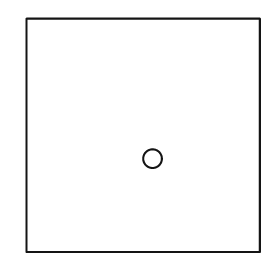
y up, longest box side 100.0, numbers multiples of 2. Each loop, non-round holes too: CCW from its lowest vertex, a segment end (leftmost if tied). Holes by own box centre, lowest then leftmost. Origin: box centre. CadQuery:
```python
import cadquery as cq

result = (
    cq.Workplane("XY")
    .moveTo(-50.0, -50.0)
    .lineTo(50.0, -50.0)
    .lineTo(50.0, 50.0)
    .lineTo(-50.0, 50.0)
    .close()
    .moveTo(4.0, -10.0)
    .circle(4.0)
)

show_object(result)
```